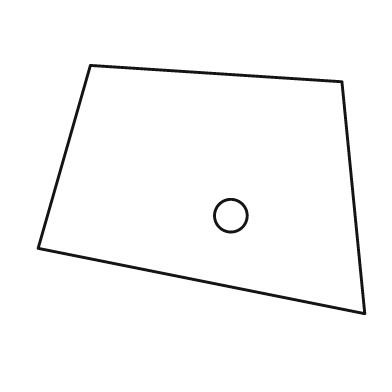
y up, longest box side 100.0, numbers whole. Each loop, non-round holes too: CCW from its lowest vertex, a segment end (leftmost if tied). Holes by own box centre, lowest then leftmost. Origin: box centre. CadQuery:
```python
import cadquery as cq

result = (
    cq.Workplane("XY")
    .moveTo(50.0, -38.0)
    .lineTo(43.0, 33.0)
    .lineTo(-34.0, 38.0)
    .lineTo(-50.0, -18.0)
    .close()
    .moveTo(9.0, -8.0)
    .circle(5.0)
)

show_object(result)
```